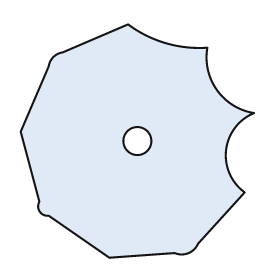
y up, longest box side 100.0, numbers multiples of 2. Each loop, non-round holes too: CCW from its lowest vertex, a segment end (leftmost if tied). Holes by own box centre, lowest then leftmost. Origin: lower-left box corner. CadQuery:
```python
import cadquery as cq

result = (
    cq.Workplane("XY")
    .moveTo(38.0, 0.0)
    .lineTo(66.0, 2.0)
    .threePointArc((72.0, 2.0), (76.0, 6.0))
    .lineTo(96.0, 28.0)
    .threePointArc((88.0, 46.0), (100.0, 62.0))
    .threePointArc((84.0, 72.0), (80.0, 90.0))
    .threePointArc((62.0, 92.0), (46.0, 100.0))
    .lineTo(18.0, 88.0)
    .threePointArc((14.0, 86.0), (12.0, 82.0))
    .lineTo(0.0, 54.0)
    .lineTo(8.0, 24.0)
    .threePointArc((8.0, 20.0), (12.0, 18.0))
    .close()
    .moveTo(50.0, 50.0)
    .circle(6.0)
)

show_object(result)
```